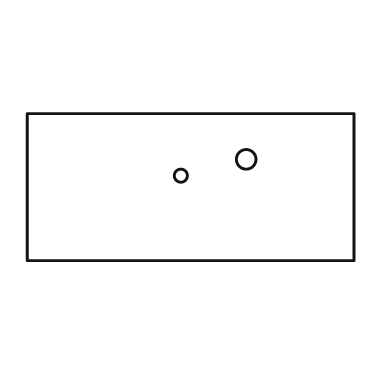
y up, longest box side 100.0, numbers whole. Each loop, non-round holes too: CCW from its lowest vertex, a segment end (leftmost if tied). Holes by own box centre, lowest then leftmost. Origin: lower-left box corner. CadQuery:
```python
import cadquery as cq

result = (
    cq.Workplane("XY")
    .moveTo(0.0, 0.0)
    .lineTo(100.0, 0.0)
    .lineTo(100.0, 45.0)
    .lineTo(0.0, 45.0)
    .close()
    .moveTo(47.0, 26.0)
    .circle(2.0)
    .moveTo(67.0, 31.0)
    .circle(3.0)
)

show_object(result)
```